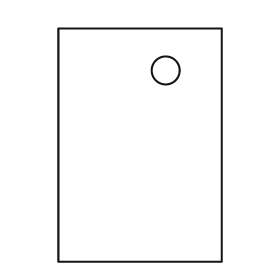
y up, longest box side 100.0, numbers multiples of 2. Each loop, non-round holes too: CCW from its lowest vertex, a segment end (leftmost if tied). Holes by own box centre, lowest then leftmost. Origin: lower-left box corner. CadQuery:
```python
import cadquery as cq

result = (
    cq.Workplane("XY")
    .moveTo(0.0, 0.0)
    .lineTo(70.0, 0.0)
    .lineTo(70.0, 100.0)
    .lineTo(0.0, 100.0)
    .close()
    .moveTo(46.0, 82.0)
    .circle(6.0)
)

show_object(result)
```